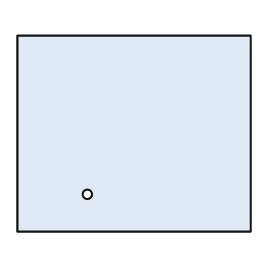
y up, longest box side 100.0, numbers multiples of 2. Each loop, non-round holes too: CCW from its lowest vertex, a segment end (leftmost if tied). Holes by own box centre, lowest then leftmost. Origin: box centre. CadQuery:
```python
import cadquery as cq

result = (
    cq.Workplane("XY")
    .moveTo(-50.0, -42.0)
    .lineTo(50.0, -42.0)
    .lineTo(50.0, 42.0)
    .lineTo(-50.0, 42.0)
    .close()
    .moveTo(-20.0, -26.0)
    .circle(2.0)
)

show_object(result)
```